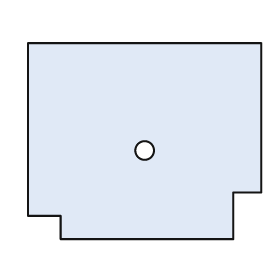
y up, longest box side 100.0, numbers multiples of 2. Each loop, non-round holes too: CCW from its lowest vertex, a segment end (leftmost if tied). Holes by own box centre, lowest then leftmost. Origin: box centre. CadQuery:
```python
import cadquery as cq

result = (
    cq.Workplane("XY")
    .moveTo(-36.0, -42.0)
    .lineTo(38.0, -42.0)
    .lineTo(38.0, -22.0)
    .lineTo(50.0, -22.0)
    .lineTo(50.0, 42.0)
    .lineTo(-50.0, 42.0)
    .lineTo(-50.0, -32.0)
    .lineTo(-36.0, -32.0)
    .close()
    .moveTo(0.0, -4.0)
    .circle(4.0)
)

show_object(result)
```